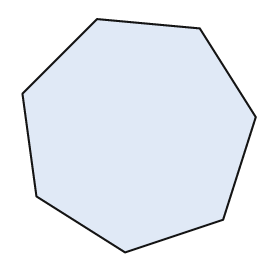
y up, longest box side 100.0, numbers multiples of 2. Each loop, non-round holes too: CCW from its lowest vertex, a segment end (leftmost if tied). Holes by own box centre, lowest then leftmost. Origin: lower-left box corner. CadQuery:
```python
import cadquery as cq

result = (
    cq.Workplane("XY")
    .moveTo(44.0, 0.0)
    .lineTo(86.0, 14.0)
    .lineTo(100.0, 58.0)
    .lineTo(76.0, 96.0)
    .lineTo(32.0, 100.0)
    .lineTo(0.0, 68.0)
    .lineTo(6.0, 24.0)
    .close()
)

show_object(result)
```